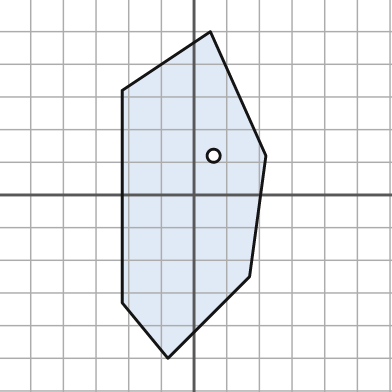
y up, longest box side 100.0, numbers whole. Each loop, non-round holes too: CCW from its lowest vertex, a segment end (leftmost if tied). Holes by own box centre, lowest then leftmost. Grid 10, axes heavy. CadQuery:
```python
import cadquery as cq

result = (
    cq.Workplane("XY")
    .moveTo(-8.0, -50.0)
    .lineTo(17.0, -25.0)
    .lineTo(22.0, 12.0)
    .lineTo(5.0, 50.0)
    .lineTo(-22.0, 32.0)
    .lineTo(-22.0, -33.0)
    .close()
    .moveTo(6.0, 12.0)
    .circle(2.0)
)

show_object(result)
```